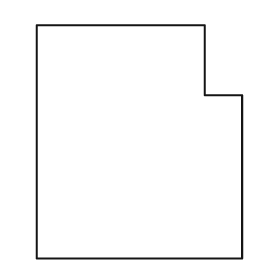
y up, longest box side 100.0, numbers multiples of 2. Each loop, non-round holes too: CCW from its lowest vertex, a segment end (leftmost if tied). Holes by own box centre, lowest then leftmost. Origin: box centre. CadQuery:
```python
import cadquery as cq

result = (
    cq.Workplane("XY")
    .moveTo(-44.0, -50.0)
    .lineTo(44.0, -50.0)
    .lineTo(44.0, 20.0)
    .lineTo(28.0, 20.0)
    .lineTo(28.0, 50.0)
    .lineTo(-44.0, 50.0)
    .close()
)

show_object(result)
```